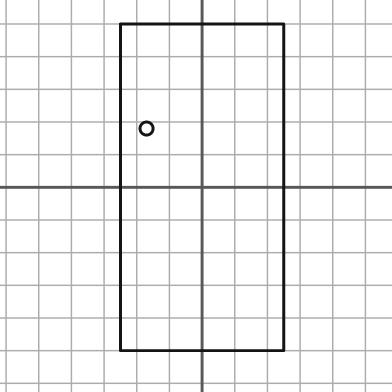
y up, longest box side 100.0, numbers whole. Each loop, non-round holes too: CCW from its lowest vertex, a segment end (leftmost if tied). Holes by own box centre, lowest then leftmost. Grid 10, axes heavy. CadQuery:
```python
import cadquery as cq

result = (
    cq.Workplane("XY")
    .moveTo(-25.0, -50.0)
    .lineTo(25.0, -50.0)
    .lineTo(25.0, 50.0)
    .lineTo(-25.0, 50.0)
    .close()
    .moveTo(-17.0, 18.0)
    .circle(2.0)
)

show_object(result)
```